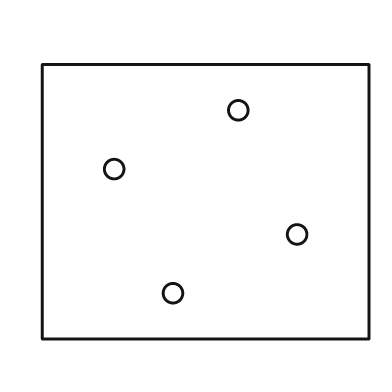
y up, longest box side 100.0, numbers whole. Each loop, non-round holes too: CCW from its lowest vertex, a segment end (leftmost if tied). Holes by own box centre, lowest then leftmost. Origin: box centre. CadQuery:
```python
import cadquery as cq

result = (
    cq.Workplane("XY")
    .moveTo(-50.0, -42.0)
    .lineTo(50.0, -42.0)
    .lineTo(50.0, 42.0)
    .lineTo(-50.0, 42.0)
    .close()
    .moveTo(-10.0, -28.0)
    .circle(3.0)
    .moveTo(28.0, -10.0)
    .circle(3.0)
    .moveTo(-28.0, 10.0)
    .circle(3.0)
    .moveTo(10.0, 28.0)
    .circle(3.0)
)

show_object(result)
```